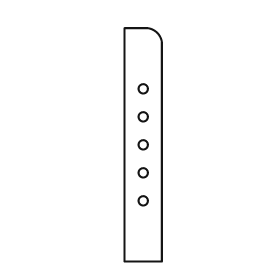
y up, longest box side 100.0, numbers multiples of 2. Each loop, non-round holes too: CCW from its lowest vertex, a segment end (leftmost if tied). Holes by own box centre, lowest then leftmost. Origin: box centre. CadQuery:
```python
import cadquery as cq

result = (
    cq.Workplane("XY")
    .moveTo(-8.0, -50.0)
    .lineTo(8.0, -50.0)
    .lineTo(8.0, 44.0)
    .threePointArc((6.0, 48.0), (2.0, 50.0))
    .lineTo(-8.0, 50.0)
    .close()
    .moveTo(0.0, -24.0)
    .circle(2.0)
    .moveTo(0.0, -12.0)
    .circle(2.0)
    .moveTo(0.0, 0.0)
    .circle(2.0)
    .moveTo(0.0, 12.0)
    .circle(2.0)
    .moveTo(0.0, 24.0)
    .circle(2.0)
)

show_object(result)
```